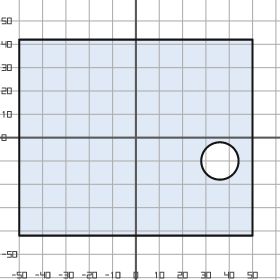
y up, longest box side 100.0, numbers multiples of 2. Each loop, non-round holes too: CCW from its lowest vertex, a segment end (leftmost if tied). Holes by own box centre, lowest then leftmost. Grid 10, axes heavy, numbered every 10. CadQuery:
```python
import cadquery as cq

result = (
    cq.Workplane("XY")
    .moveTo(-50.0, -42.0)
    .lineTo(50.0, -42.0)
    .lineTo(50.0, 42.0)
    .lineTo(-50.0, 42.0)
    .close()
    .moveTo(36.0, -10.0)
    .circle(8.0)
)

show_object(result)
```